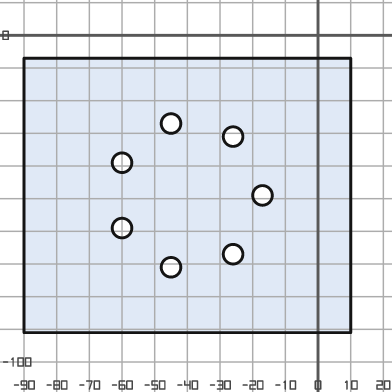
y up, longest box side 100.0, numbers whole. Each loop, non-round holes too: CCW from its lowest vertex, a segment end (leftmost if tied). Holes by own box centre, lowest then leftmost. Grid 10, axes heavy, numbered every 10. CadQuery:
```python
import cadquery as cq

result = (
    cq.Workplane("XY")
    .moveTo(-90.0, -91.0)
    .lineTo(10.0, -91.0)
    .lineTo(10.0, -7.0)
    .lineTo(-90.0, -7.0)
    .close()
    .moveTo(-45.0, -71.0)
    .circle(3.0)
    .moveTo(-26.0, -67.0)
    .circle(3.0)
    .moveTo(-60.0, -59.0)
    .circle(3.0)
    .moveTo(-17.0, -49.0)
    .circle(3.0)
    .moveTo(-60.0, -39.0)
    .circle(3.0)
    .moveTo(-26.0, -31.0)
    .circle(3.0)
    .moveTo(-45.0, -27.0)
    .circle(3.0)
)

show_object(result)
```